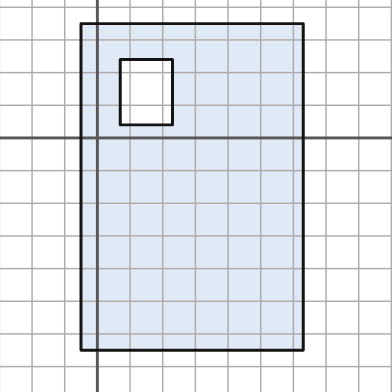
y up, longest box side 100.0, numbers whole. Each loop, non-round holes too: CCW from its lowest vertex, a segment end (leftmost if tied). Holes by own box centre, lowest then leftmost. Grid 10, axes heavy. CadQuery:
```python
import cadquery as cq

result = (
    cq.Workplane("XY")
    .moveTo(-5.0, -65.0)
    .lineTo(63.0, -65.0)
    .lineTo(63.0, 35.0)
    .lineTo(-5.0, 35.0)
    .close()
    .moveTo(7.0, 4.0)
    .lineTo(23.0, 4.0)
    .lineTo(23.0, 24.0)
    .lineTo(7.0, 24.0)
    .close()
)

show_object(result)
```